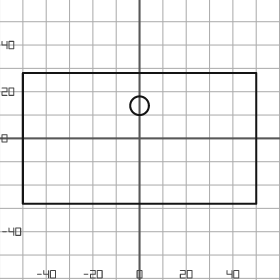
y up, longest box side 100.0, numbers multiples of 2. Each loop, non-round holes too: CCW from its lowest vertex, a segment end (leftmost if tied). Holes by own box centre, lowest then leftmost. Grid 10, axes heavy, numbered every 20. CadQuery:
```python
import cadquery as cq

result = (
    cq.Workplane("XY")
    .moveTo(-50.0, -28.0)
    .lineTo(50.0, -28.0)
    .lineTo(50.0, 28.0)
    .lineTo(-50.0, 28.0)
    .close()
    .moveTo(0.0, 14.0)
    .circle(4.0)
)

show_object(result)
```